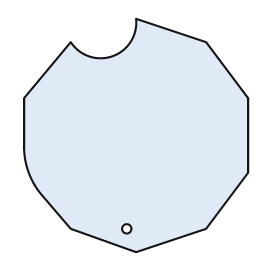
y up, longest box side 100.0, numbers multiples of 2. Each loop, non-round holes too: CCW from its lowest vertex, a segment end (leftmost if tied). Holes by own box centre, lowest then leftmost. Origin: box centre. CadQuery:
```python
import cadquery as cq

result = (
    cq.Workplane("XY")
    .moveTo(0.0, -50.0)
    .lineTo(30.0, -40.0)
    .lineTo(48.0, -16.0)
    .lineTo(48.0, 16.0)
    .lineTo(30.0, 40.0)
    .lineTo(0.0, 50.0)
    .threePointArc((-10.0, 34.0), (-28.0, 40.0))
    .lineTo(-48.0, 16.0)
    .lineTo(-48.0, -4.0)
    .threePointArc((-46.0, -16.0), (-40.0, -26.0))
    .lineTo(-28.0, -40.0)
    .close()
    .moveTo(-4.0, -40.0)
    .circle(2.0)
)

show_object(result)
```